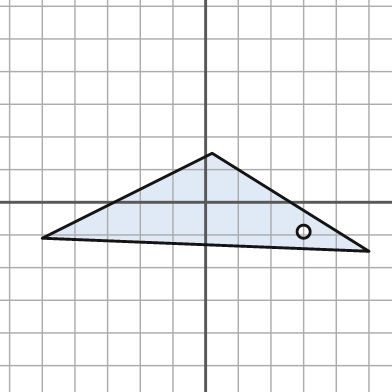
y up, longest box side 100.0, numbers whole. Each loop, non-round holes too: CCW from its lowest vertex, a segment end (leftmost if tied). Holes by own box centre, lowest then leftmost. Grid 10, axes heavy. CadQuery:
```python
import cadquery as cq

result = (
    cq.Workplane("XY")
    .moveTo(50.0, -15.0)
    .lineTo(2.0, 15.0)
    .lineTo(-50.0, -11.0)
    .close()
    .moveTo(30.0, -9.0)
    .circle(2.0)
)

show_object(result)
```